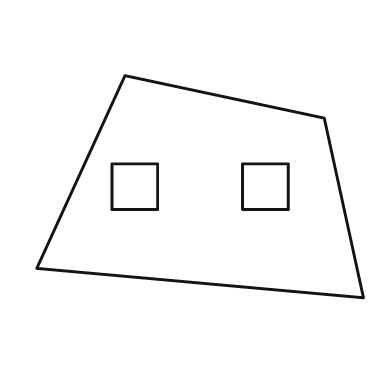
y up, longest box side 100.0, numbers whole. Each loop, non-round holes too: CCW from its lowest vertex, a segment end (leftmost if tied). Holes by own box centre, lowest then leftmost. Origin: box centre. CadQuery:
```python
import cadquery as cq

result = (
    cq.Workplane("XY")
    .moveTo(50.0, -34.0)
    .lineTo(38.0, 21.0)
    .lineTo(-23.0, 34.0)
    .lineTo(-50.0, -25.0)
    .close()
    .moveTo(-27.0, -7.0)
    .lineTo(-13.0, -7.0)
    .lineTo(-13.0, 7.0)
    .lineTo(-27.0, 7.0)
    .close()
    .moveTo(13.0, -7.0)
    .lineTo(27.0, -7.0)
    .lineTo(27.0, 7.0)
    .lineTo(13.0, 7.0)
    .close()
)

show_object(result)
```